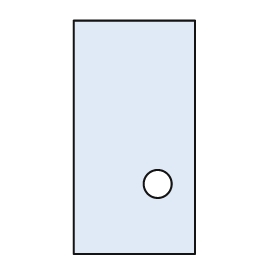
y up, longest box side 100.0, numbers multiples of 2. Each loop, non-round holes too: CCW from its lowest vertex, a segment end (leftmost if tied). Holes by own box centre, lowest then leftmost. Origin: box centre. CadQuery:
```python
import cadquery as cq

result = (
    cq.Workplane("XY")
    .moveTo(-26.0, -50.0)
    .lineTo(26.0, -50.0)
    .lineTo(26.0, 50.0)
    .lineTo(-26.0, 50.0)
    .close()
    .moveTo(10.0, -20.0)
    .circle(6.0)
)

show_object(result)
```